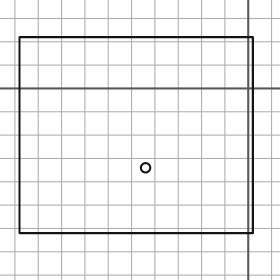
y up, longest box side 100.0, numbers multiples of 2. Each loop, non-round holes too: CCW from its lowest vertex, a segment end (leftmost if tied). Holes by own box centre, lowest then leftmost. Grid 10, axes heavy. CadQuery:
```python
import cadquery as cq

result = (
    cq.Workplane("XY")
    .moveTo(-98.0, -62.0)
    .lineTo(2.0, -62.0)
    .lineTo(2.0, 22.0)
    .lineTo(-98.0, 22.0)
    .close()
    .moveTo(-44.0, -34.0)
    .circle(2.0)
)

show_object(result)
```